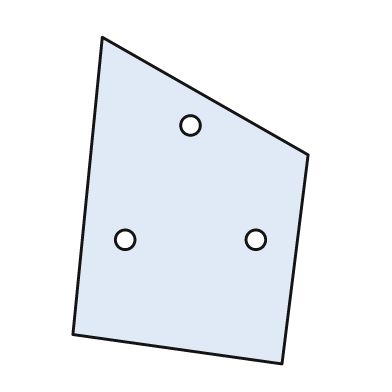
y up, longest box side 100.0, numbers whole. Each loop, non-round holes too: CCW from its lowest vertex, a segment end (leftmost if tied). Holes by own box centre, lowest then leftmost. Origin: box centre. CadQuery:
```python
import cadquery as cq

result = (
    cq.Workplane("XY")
    .moveTo(28.0, -50.0)
    .lineTo(36.0, 14.0)
    .lineTo(-27.0, 50.0)
    .lineTo(-36.0, -41.0)
    .close()
    .moveTo(-20.0, -12.0)
    .circle(3.0)
    .moveTo(20.0, -12.0)
    .circle(3.0)
    .moveTo(0.0, 23.0)
    .circle(3.0)
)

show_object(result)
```